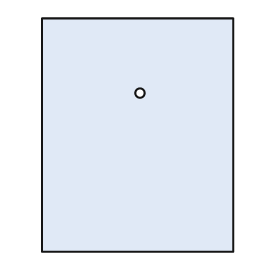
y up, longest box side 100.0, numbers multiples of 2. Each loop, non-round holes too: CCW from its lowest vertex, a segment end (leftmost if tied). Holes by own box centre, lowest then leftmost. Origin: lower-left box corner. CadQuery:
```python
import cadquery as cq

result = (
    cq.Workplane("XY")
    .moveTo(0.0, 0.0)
    .lineTo(82.0, 0.0)
    .lineTo(82.0, 100.0)
    .lineTo(0.0, 100.0)
    .close()
    .moveTo(42.0, 68.0)
    .circle(2.0)
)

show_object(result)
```